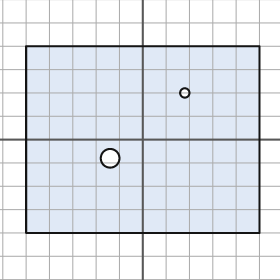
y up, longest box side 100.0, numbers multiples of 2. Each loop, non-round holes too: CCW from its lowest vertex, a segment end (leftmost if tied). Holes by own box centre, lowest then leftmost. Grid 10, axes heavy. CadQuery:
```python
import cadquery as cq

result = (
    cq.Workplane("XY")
    .moveTo(-50.0, -40.0)
    .lineTo(50.0, -40.0)
    .lineTo(50.0, 40.0)
    .lineTo(-50.0, 40.0)
    .close()
    .moveTo(-14.0, -8.0)
    .circle(4.0)
    .moveTo(18.0, 20.0)
    .circle(2.0)
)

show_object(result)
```